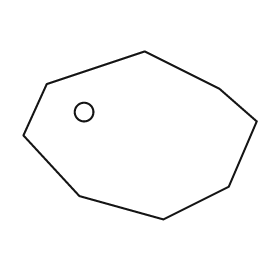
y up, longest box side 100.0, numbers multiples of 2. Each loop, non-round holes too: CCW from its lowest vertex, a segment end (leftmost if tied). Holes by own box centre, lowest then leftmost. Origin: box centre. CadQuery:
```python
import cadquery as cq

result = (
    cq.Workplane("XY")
    .moveTo(10.0, -36.0)
    .lineTo(38.0, -22.0)
    .lineTo(50.0, 6.0)
    .lineTo(34.0, 20.0)
    .lineTo(2.0, 36.0)
    .lineTo(-40.0, 22.0)
    .lineTo(-50.0, 0.0)
    .lineTo(-26.0, -26.0)
    .close()
    .moveTo(-24.0, 10.0)
    .circle(4.0)
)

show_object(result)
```